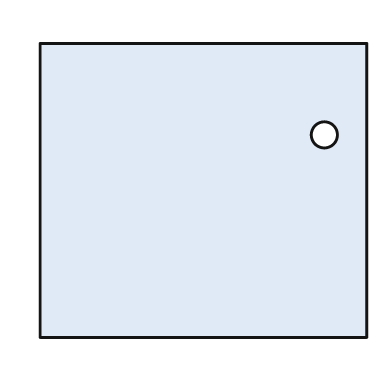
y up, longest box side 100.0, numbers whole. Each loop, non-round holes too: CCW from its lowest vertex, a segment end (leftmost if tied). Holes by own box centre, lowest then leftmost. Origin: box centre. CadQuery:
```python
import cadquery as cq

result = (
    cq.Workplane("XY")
    .moveTo(-50.0, -45.0)
    .lineTo(50.0, -45.0)
    .lineTo(50.0, 45.0)
    .lineTo(-50.0, 45.0)
    .close()
    .moveTo(37.0, 17.0)
    .circle(4.0)
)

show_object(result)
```